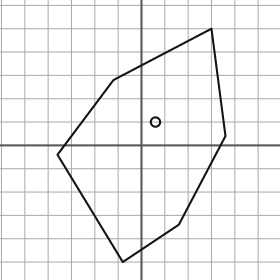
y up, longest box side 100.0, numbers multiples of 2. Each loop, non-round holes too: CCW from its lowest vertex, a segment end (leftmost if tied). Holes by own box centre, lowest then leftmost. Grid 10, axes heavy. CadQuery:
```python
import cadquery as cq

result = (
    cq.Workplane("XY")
    .moveTo(-8.0, -50.0)
    .lineTo(16.0, -34.0)
    .lineTo(36.0, 4.0)
    .lineTo(30.0, 50.0)
    .lineTo(-12.0, 28.0)
    .lineTo(-36.0, -4.0)
    .close()
    .moveTo(6.0, 10.0)
    .circle(2.0)
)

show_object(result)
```